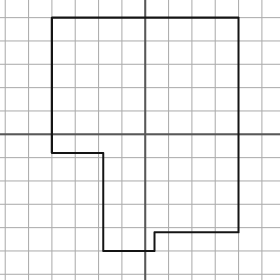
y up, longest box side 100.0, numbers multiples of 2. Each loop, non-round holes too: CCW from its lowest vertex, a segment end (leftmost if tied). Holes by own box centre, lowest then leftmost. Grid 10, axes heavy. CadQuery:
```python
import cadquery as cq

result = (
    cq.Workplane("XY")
    .moveTo(-18.0, -50.0)
    .lineTo(4.0, -50.0)
    .lineTo(4.0, -42.0)
    .lineTo(40.0, -42.0)
    .lineTo(40.0, 50.0)
    .lineTo(-40.0, 50.0)
    .lineTo(-40.0, -8.0)
    .lineTo(-18.0, -8.0)
    .close()
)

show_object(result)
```